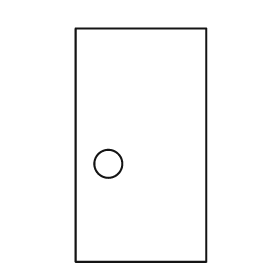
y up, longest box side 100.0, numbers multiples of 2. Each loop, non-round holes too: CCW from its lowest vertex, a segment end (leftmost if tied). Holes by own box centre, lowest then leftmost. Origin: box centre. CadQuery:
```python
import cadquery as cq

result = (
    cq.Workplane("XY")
    .moveTo(-28.0, -50.0)
    .lineTo(28.0, -50.0)
    .lineTo(28.0, 50.0)
    .lineTo(-28.0, 50.0)
    .close()
    .moveTo(-14.0, -8.0)
    .circle(6.0)
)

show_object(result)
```